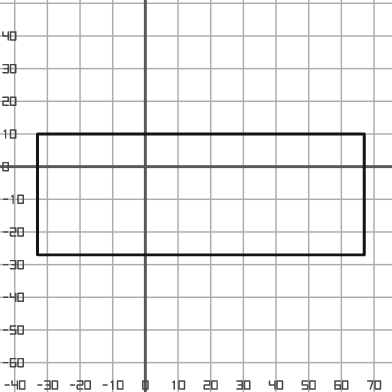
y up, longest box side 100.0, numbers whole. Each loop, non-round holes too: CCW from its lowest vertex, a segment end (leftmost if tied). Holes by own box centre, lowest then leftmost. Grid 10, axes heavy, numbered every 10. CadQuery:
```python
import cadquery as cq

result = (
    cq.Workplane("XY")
    .moveTo(-33.0, -27.0)
    .lineTo(67.0, -27.0)
    .lineTo(67.0, 10.0)
    .lineTo(-33.0, 10.0)
    .close()
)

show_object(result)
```